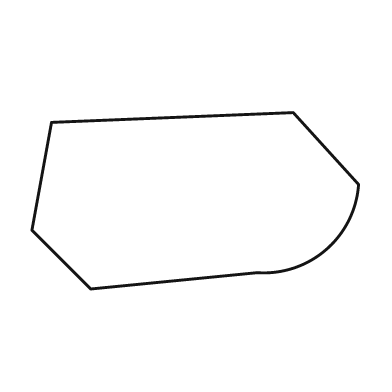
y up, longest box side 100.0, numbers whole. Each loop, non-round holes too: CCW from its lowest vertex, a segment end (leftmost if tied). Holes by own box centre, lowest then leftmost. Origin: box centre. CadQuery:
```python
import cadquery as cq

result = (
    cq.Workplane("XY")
    .moveTo(-32.0, -27.0)
    .lineTo(19.0, -22.0)
    .threePointArc((40.0, -15.0), (50.0, 5.0))
    .lineTo(30.0, 27.0)
    .lineTo(-44.0, 24.0)
    .lineTo(-50.0, -9.0)
    .close()
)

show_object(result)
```